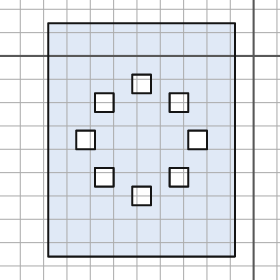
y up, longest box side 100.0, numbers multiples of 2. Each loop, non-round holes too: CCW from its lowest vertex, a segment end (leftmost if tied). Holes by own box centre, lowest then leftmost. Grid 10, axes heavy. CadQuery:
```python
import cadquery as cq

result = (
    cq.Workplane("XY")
    .moveTo(-88.0, -86.0)
    .lineTo(-8.0, -86.0)
    .lineTo(-8.0, 14.0)
    .lineTo(-88.0, 14.0)
    .close()
    .moveTo(-52.0, -64.0)
    .lineTo(-44.0, -64.0)
    .lineTo(-44.0, -56.0)
    .lineTo(-52.0, -56.0)
    .close()
    .moveTo(-68.0, -56.0)
    .lineTo(-60.0, -56.0)
    .lineTo(-60.0, -48.0)
    .lineTo(-68.0, -48.0)
    .close()
    .moveTo(-36.0, -56.0)
    .lineTo(-28.0, -56.0)
    .lineTo(-28.0, -48.0)
    .lineTo(-36.0, -48.0)
    .close()
    .moveTo(-76.0, -40.0)
    .lineTo(-68.0, -40.0)
    .lineTo(-68.0, -32.0)
    .lineTo(-76.0, -32.0)
    .close()
    .moveTo(-28.0, -40.0)
    .lineTo(-20.0, -40.0)
    .lineTo(-20.0, -32.0)
    .lineTo(-28.0, -32.0)
    .close()
    .moveTo(-68.0, -24.0)
    .lineTo(-60.0, -24.0)
    .lineTo(-60.0, -16.0)
    .lineTo(-68.0, -16.0)
    .close()
    .moveTo(-36.0, -24.0)
    .lineTo(-28.0, -24.0)
    .lineTo(-28.0, -16.0)
    .lineTo(-36.0, -16.0)
    .close()
    .moveTo(-52.0, -16.0)
    .lineTo(-44.0, -16.0)
    .lineTo(-44.0, -8.0)
    .lineTo(-52.0, -8.0)
    .close()
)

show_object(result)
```